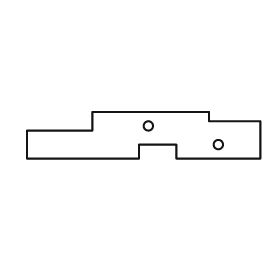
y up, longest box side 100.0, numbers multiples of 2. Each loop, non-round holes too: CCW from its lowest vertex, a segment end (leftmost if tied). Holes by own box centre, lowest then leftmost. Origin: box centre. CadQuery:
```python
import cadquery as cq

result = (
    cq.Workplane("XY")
    .moveTo(-50.0, -10.0)
    .lineTo(-2.0, -10.0)
    .lineTo(-2.0, -4.0)
    .lineTo(14.0, -4.0)
    .lineTo(14.0, -10.0)
    .lineTo(50.0, -10.0)
    .lineTo(50.0, 6.0)
    .lineTo(28.0, 6.0)
    .lineTo(28.0, 10.0)
    .lineTo(-22.0, 10.0)
    .lineTo(-22.0, 2.0)
    .lineTo(-50.0, 2.0)
    .close()
    .moveTo(32.0, -4.0)
    .circle(2.0)
    .moveTo(2.0, 4.0)
    .circle(2.0)
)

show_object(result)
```